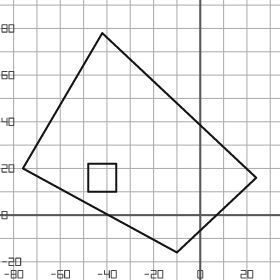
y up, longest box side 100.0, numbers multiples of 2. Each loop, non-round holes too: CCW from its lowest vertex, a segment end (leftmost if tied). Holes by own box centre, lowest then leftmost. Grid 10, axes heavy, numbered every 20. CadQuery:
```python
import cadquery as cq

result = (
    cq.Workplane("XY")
    .moveTo(-10.0, -16.0)
    .lineTo(24.0, 16.0)
    .lineTo(-42.0, 78.0)
    .lineTo(-76.0, 20.0)
    .close()
    .moveTo(-48.0, 10.0)
    .lineTo(-36.0, 10.0)
    .lineTo(-36.0, 22.0)
    .lineTo(-48.0, 22.0)
    .close()
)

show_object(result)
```